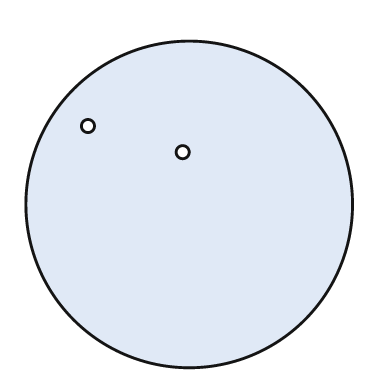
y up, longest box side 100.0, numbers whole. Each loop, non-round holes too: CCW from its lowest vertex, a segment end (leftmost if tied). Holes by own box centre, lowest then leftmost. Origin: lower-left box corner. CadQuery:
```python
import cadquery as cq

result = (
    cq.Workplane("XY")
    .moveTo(50.0, 50.0)
    .circle(50.0)
    .moveTo(48.0, 66.0)
    .circle(2.0)
    .moveTo(19.0, 74.0)
    .circle(2.0)
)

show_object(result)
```